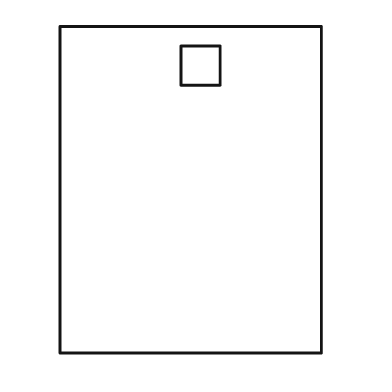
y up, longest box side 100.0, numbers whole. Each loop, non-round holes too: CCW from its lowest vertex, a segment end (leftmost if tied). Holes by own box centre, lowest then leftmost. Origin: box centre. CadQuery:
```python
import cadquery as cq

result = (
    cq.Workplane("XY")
    .moveTo(-40.0, -50.0)
    .lineTo(40.0, -50.0)
    .lineTo(40.0, 50.0)
    .lineTo(-40.0, 50.0)
    .close()
    .moveTo(-3.0, 32.0)
    .lineTo(9.0, 32.0)
    .lineTo(9.0, 44.0)
    .lineTo(-3.0, 44.0)
    .close()
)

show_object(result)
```